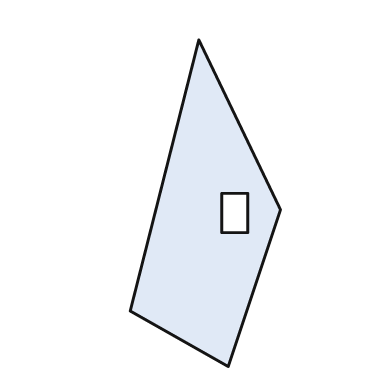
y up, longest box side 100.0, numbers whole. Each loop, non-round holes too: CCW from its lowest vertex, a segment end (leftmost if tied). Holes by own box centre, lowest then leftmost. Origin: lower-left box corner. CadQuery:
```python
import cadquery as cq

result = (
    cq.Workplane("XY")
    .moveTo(30.0, 0.0)
    .lineTo(46.0, 48.0)
    .lineTo(21.0, 100.0)
    .lineTo(0.0, 17.0)
    .close()
    .moveTo(28.0, 41.0)
    .lineTo(36.0, 41.0)
    .lineTo(36.0, 53.0)
    .lineTo(28.0, 53.0)
    .close()
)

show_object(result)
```